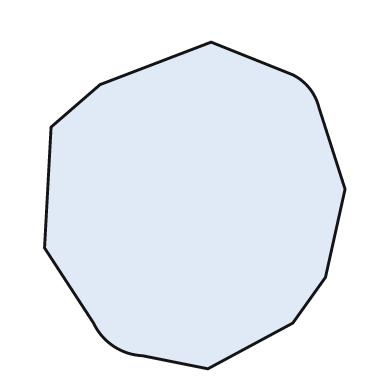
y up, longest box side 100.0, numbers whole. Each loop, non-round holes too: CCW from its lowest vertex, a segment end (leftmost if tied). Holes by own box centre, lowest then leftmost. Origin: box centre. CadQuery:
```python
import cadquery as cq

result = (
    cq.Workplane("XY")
    .moveTo(4.0, -50.0)
    .lineTo(30.0, -36.0)
    .lineTo(40.0, -22.0)
    .lineTo(46.0, 5.0)
    .lineTo(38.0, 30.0)
    .threePointArc((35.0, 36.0), (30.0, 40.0))
    .lineTo(5.0, 50.0)
    .lineTo(-29.0, 37.0)
    .lineTo(-44.0, 24.0)
    .lineTo(-46.0, -13.0)
    .lineTo(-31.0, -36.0)
    .threePointArc((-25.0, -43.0), (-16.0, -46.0))
    .close()
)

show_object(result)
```